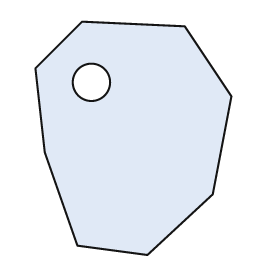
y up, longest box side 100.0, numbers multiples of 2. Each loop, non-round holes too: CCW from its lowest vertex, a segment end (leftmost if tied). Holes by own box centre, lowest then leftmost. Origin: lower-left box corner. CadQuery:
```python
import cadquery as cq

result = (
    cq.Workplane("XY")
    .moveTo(48.0, 0.0)
    .lineTo(76.0, 26.0)
    .lineTo(84.0, 68.0)
    .lineTo(64.0, 98.0)
    .lineTo(20.0, 100.0)
    .lineTo(0.0, 80.0)
    .lineTo(4.0, 44.0)
    .lineTo(18.0, 4.0)
    .close()
    .moveTo(24.0, 74.0)
    .circle(8.0)
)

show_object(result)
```